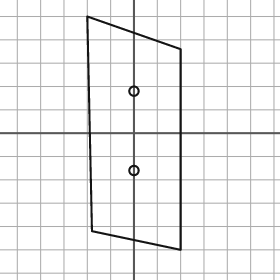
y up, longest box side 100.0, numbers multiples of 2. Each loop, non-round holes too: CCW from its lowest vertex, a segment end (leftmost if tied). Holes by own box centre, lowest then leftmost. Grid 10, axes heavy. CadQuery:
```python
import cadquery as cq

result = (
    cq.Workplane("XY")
    .moveTo(20.0, -50.0)
    .lineTo(20.0, 36.0)
    .lineTo(-20.0, 50.0)
    .lineTo(-18.0, -42.0)
    .close()
    .moveTo(0.0, -16.0)
    .circle(2.0)
    .moveTo(0.0, 18.0)
    .circle(2.0)
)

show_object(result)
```